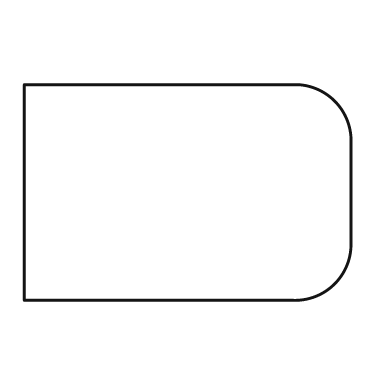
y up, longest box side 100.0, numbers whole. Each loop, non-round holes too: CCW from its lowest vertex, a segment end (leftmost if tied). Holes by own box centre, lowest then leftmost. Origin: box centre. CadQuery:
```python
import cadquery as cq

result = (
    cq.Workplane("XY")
    .moveTo(-50.0, -33.0)
    .lineTo(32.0, -33.0)
    .threePointArc((45.0, -28.0), (50.0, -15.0))
    .lineTo(50.0, 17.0)
    .threePointArc((45.0, 28.0), (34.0, 33.0))
    .lineTo(-50.0, 33.0)
    .close()
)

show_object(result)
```